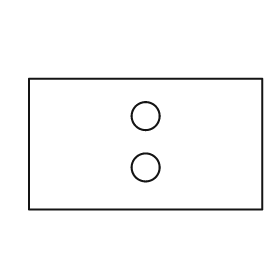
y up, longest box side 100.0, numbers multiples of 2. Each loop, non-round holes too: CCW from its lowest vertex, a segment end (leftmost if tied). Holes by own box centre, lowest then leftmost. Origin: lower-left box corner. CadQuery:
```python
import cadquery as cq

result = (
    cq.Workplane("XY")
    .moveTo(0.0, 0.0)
    .lineTo(100.0, 0.0)
    .lineTo(100.0, 56.0)
    .lineTo(0.0, 56.0)
    .close()
    .moveTo(50.0, 18.0)
    .circle(6.0)
    .moveTo(50.0, 40.0)
    .circle(6.0)
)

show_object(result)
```